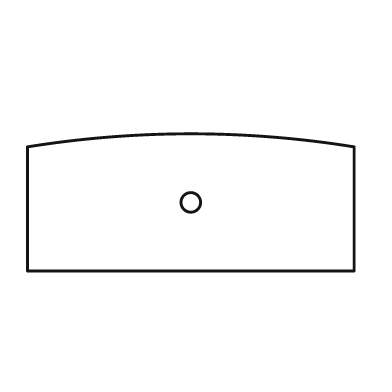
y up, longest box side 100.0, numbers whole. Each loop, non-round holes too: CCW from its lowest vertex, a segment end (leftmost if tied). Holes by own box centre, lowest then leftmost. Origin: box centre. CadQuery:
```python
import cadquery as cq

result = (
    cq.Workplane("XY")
    .moveTo(-50.0, -21.0)
    .lineTo(50.0, -21.0)
    .lineTo(50.0, 17.0)
    .threePointArc((0.0, 21.0), (-50.0, 17.0))
    .close()
    .moveTo(0.0, 0.0)
    .circle(3.0)
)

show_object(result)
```